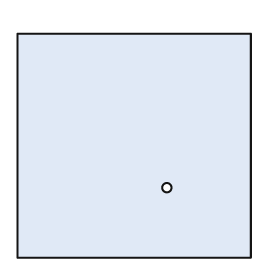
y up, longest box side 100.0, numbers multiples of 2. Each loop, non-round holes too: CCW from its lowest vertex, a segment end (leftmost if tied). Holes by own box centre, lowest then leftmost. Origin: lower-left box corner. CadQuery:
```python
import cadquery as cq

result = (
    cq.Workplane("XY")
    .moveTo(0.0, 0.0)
    .lineTo(100.0, 0.0)
    .lineTo(100.0, 96.0)
    .lineTo(0.0, 96.0)
    .close()
    .moveTo(64.0, 30.0)
    .circle(2.0)
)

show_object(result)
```